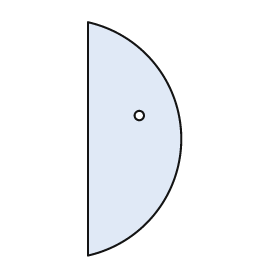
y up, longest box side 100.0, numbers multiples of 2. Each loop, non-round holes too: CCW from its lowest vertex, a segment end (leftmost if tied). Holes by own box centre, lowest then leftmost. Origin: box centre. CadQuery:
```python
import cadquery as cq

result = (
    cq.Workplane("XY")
    .moveTo(-20.0, -50.0)
    .threePointArc((20.0, 0.0), (-20.0, 50.0))
    .close()
    .moveTo(2.0, 10.0)
    .circle(2.0)
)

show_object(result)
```